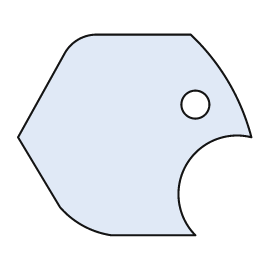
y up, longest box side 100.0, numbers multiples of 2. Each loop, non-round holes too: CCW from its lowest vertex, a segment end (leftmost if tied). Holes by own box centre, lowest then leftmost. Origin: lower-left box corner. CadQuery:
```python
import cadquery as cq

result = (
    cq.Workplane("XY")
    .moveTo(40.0, 0.0)
    .lineTo(76.0, 0.0)
    .threePointArc((72.0, 30.0), (100.0, 42.0))
    .threePointArc((90.0, 66.0), (74.0, 86.0))
    .lineTo(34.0, 86.0)
    .threePointArc((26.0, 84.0), (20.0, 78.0))
    .lineTo(0.0, 42.0)
    .lineTo(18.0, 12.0)
    .threePointArc((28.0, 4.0), (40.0, 0.0))
    .close()
    .moveTo(76.0, 56.0)
    .circle(6.0)
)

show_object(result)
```